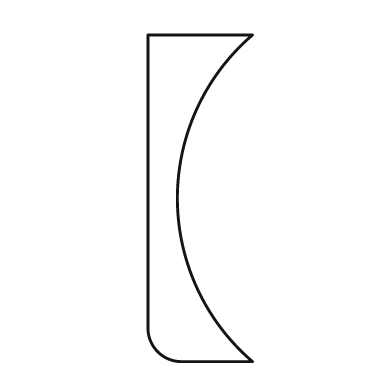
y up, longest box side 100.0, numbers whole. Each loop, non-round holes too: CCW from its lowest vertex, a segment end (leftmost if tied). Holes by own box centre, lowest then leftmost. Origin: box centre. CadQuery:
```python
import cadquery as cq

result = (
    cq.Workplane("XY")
    .moveTo(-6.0, -50.0)
    .lineTo(16.0, -50.0)
    .threePointArc((-7.0, 0.0), (16.0, 50.0))
    .lineTo(-16.0, 50.0)
    .lineTo(-16.0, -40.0)
    .threePointArc((-13.0, -47.0), (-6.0, -50.0))
    .close()
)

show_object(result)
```